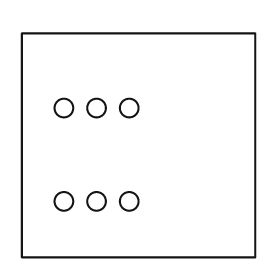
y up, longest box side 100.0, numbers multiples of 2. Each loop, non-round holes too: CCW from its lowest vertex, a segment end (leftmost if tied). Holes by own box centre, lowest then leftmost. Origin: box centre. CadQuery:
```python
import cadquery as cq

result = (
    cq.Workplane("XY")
    .moveTo(-50.0, -48.0)
    .lineTo(50.0, -48.0)
    .lineTo(50.0, 48.0)
    .lineTo(-50.0, 48.0)
    .close()
    .moveTo(-32.0, -24.0)
    .circle(4.0)
    .moveTo(-18.0, -24.0)
    .circle(4.0)
    .moveTo(-4.0, -24.0)
    .circle(4.0)
    .moveTo(-32.0, 16.0)
    .circle(4.0)
    .moveTo(-18.0, 16.0)
    .circle(4.0)
    .moveTo(-4.0, 16.0)
    .circle(4.0)
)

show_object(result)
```